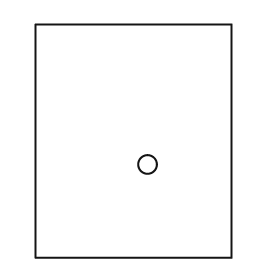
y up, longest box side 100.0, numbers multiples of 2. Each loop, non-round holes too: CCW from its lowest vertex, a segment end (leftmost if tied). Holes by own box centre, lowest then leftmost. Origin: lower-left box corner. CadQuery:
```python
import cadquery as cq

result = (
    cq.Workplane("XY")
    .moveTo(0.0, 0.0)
    .lineTo(84.0, 0.0)
    .lineTo(84.0, 100.0)
    .lineTo(0.0, 100.0)
    .close()
    .moveTo(48.0, 40.0)
    .circle(4.0)
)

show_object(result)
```